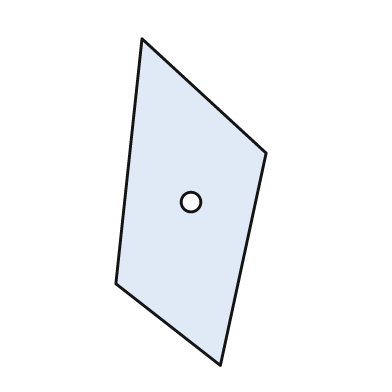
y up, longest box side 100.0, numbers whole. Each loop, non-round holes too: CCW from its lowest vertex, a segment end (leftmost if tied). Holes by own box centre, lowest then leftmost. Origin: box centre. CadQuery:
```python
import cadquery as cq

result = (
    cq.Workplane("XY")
    .moveTo(9.0, -50.0)
    .lineTo(23.0, 15.0)
    .lineTo(-15.0, 50.0)
    .lineTo(-23.0, -25.0)
    .close()
    .moveTo(0.0, 0.0)
    .circle(3.0)
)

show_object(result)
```